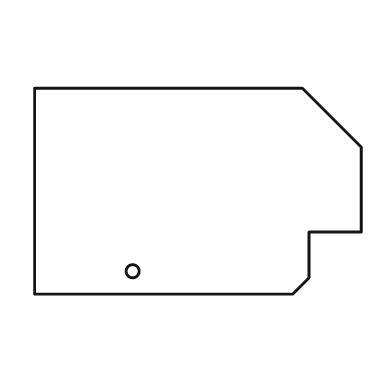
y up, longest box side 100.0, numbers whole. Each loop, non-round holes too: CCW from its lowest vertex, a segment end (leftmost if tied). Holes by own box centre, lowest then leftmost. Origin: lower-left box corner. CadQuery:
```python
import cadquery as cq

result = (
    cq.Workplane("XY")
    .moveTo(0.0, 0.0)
    .lineTo(79.0, 0.0)
    .lineTo(84.0, 5.0)
    .lineTo(84.0, 19.0)
    .lineTo(100.0, 19.0)
    .lineTo(100.0, 45.0)
    .lineTo(82.0, 63.0)
    .lineTo(0.0, 63.0)
    .close()
    .moveTo(30.0, 7.0)
    .circle(2.0)
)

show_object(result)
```